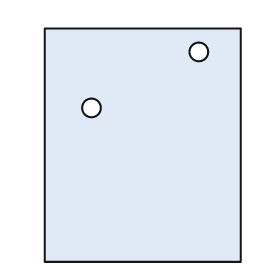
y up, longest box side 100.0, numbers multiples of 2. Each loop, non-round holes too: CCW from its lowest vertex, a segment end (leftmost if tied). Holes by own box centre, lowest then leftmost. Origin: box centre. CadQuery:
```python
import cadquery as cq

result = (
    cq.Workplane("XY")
    .moveTo(-42.0, -50.0)
    .lineTo(42.0, -50.0)
    .lineTo(42.0, 50.0)
    .lineTo(-42.0, 50.0)
    .close()
    .moveTo(-22.0, 16.0)
    .circle(4.0)
    .moveTo(24.0, 40.0)
    .circle(4.0)
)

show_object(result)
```